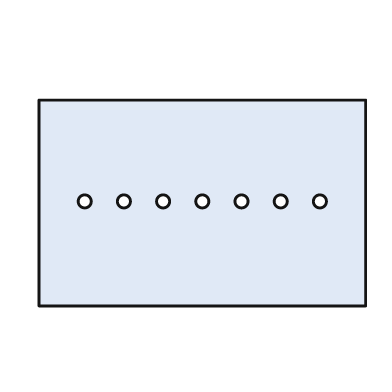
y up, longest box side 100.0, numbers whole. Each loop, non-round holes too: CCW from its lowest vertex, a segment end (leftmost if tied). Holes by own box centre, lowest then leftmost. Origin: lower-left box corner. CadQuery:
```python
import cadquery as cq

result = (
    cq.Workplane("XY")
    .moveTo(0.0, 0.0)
    .lineTo(100.0, 0.0)
    .lineTo(100.0, 63.0)
    .lineTo(0.0, 63.0)
    .close()
    .moveTo(14.0, 32.0)
    .circle(2.0)
    .moveTo(26.0, 32.0)
    .circle(2.0)
    .moveTo(38.0, 32.0)
    .circle(2.0)
    .moveTo(50.0, 32.0)
    .circle(2.0)
    .moveTo(62.0, 32.0)
    .circle(2.0)
    .moveTo(74.0, 32.0)
    .circle(2.0)
    .moveTo(86.0, 32.0)
    .circle(2.0)
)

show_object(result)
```